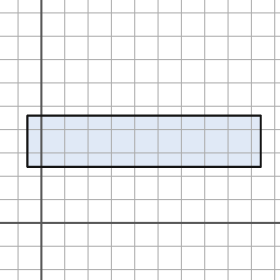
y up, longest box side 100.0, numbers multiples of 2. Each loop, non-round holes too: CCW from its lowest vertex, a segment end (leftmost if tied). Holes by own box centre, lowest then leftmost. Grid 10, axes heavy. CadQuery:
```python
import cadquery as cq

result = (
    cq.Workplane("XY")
    .moveTo(-6.0, 24.0)
    .lineTo(94.0, 24.0)
    .lineTo(94.0, 46.0)
    .lineTo(-6.0, 46.0)
    .close()
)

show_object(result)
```